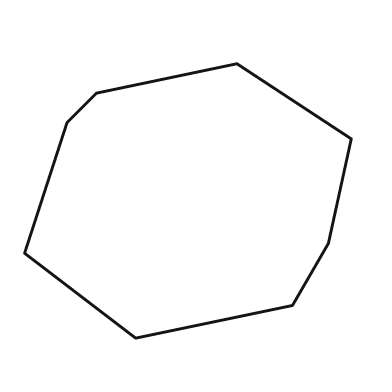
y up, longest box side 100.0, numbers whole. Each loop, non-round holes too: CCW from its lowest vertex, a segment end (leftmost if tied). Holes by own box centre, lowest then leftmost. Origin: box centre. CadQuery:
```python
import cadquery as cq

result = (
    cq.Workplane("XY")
    .moveTo(-16.0, -42.0)
    .lineTo(32.0, -32.0)
    .lineTo(43.0, -13.0)
    .lineTo(50.0, 19.0)
    .lineTo(15.0, 42.0)
    .lineTo(-28.0, 33.0)
    .lineTo(-37.0, 24.0)
    .lineTo(-50.0, -16.0)
    .close()
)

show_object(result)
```